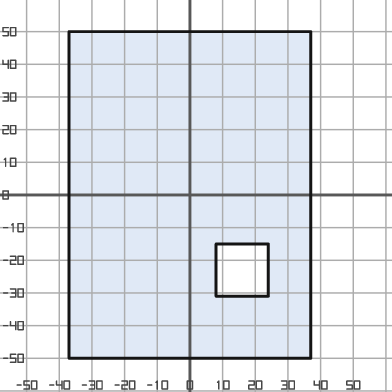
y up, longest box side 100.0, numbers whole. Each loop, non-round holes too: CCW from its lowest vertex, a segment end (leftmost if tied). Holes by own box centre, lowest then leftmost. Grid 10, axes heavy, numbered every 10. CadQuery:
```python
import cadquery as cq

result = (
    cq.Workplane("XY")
    .moveTo(-37.0, -50.0)
    .lineTo(37.0, -50.0)
    .lineTo(37.0, 50.0)
    .lineTo(-37.0, 50.0)
    .close()
    .moveTo(8.0, -31.0)
    .lineTo(24.0, -31.0)
    .lineTo(24.0, -15.0)
    .lineTo(8.0, -15.0)
    .close()
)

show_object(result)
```